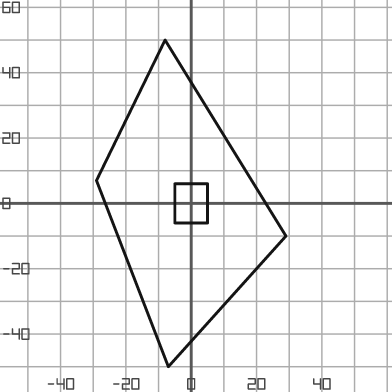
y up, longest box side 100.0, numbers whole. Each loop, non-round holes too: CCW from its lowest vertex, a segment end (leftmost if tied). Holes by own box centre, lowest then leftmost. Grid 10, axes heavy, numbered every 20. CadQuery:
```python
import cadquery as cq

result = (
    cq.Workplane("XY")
    .moveTo(-7.0, -50.0)
    .lineTo(29.0, -10.0)
    .lineTo(-8.0, 50.0)
    .lineTo(-29.0, 7.0)
    .close()
    .moveTo(-5.0, -6.0)
    .lineTo(5.0, -6.0)
    .lineTo(5.0, 6.0)
    .lineTo(-5.0, 6.0)
    .close()
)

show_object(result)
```